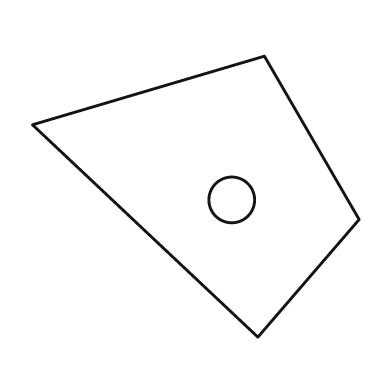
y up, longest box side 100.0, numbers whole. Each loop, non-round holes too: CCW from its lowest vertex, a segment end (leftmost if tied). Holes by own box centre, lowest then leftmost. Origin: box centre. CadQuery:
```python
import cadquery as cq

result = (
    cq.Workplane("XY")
    .moveTo(19.0, -43.0)
    .lineTo(50.0, -7.0)
    .lineTo(21.0, 43.0)
    .lineTo(-50.0, 22.0)
    .close()
    .moveTo(11.0, -1.0)
    .circle(7.0)
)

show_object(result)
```